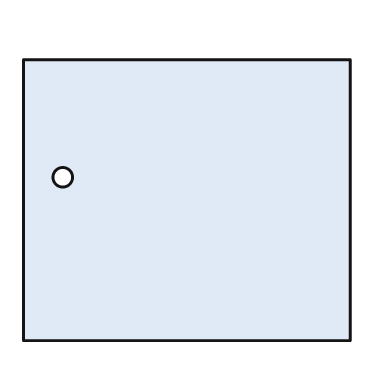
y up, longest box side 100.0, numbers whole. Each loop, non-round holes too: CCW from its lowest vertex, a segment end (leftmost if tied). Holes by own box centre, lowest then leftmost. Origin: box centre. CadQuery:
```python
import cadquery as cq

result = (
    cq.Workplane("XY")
    .moveTo(-50.0, -43.0)
    .lineTo(50.0, -43.0)
    .lineTo(50.0, 43.0)
    .lineTo(-50.0, 43.0)
    .close()
    .moveTo(-38.0, 7.0)
    .circle(3.0)
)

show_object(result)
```